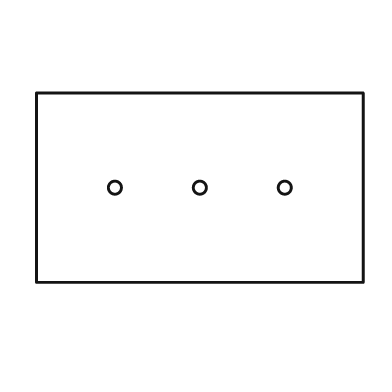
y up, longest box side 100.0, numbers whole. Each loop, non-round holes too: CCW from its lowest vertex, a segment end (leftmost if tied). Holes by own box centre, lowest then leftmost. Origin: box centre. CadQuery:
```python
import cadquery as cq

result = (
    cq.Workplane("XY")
    .moveTo(-50.0, -29.0)
    .lineTo(50.0, -29.0)
    .lineTo(50.0, 29.0)
    .lineTo(-50.0, 29.0)
    .close()
    .moveTo(-26.0, 0.0)
    .circle(2.0)
    .moveTo(0.0, 0.0)
    .circle(2.0)
    .moveTo(26.0, 0.0)
    .circle(2.0)
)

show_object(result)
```